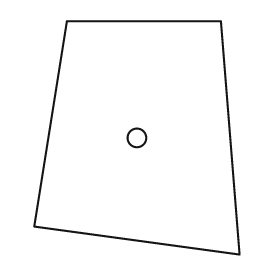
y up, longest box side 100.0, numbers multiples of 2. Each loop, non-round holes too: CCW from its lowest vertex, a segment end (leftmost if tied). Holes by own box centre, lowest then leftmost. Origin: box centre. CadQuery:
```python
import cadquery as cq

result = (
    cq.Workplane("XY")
    .moveTo(44.0, -50.0)
    .lineTo(36.0, 50.0)
    .lineTo(-30.0, 50.0)
    .lineTo(-44.0, -38.0)
    .close()
    .moveTo(0.0, 0.0)
    .circle(4.0)
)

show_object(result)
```